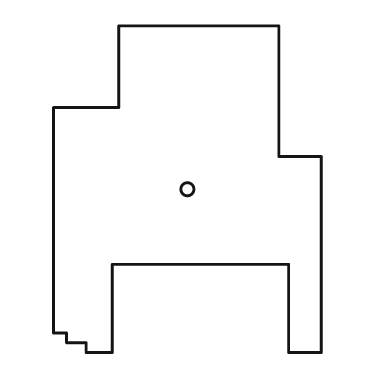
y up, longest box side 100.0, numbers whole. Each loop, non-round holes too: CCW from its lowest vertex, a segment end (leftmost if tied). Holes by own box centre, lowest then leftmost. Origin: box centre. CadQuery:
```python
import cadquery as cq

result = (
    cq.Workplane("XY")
    .moveTo(-31.0, -50.0)
    .lineTo(-23.0, -50.0)
    .lineTo(-23.0, -23.0)
    .lineTo(31.0, -23.0)
    .lineTo(31.0, -50.0)
    .lineTo(41.0, -50.0)
    .lineTo(41.0, 10.0)
    .lineTo(28.0, 10.0)
    .lineTo(28.0, 50.0)
    .lineTo(-21.0, 50.0)
    .lineTo(-21.0, 25.0)
    .lineTo(-41.0, 25.0)
    .lineTo(-41.0, -44.0)
    .lineTo(-37.0, -44.0)
    .lineTo(-37.0, -47.0)
    .lineTo(-31.0, -47.0)
    .close()
    .moveTo(0.0, 0.0)
    .circle(2.0)
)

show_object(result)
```